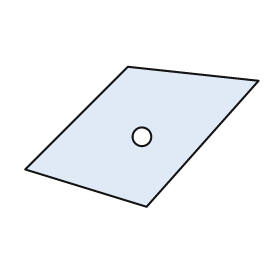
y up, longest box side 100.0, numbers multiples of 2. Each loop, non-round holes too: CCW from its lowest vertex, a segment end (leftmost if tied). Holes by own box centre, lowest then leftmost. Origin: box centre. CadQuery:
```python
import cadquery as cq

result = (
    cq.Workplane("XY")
    .moveTo(2.0, -30.0)
    .lineTo(50.0, 24.0)
    .lineTo(-6.0, 30.0)
    .lineTo(-50.0, -14.0)
    .close()
    .moveTo(0.0, 0.0)
    .circle(4.0)
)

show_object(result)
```